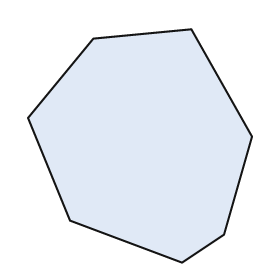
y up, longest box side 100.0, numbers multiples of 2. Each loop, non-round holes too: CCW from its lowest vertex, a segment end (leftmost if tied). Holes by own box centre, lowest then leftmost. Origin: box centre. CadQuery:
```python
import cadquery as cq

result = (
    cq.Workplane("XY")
    .moveTo(18.0, -50.0)
    .lineTo(36.0, -38.0)
    .lineTo(48.0, 4.0)
    .lineTo(22.0, 50.0)
    .lineTo(-20.0, 46.0)
    .lineTo(-48.0, 12.0)
    .lineTo(-30.0, -32.0)
    .close()
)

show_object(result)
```